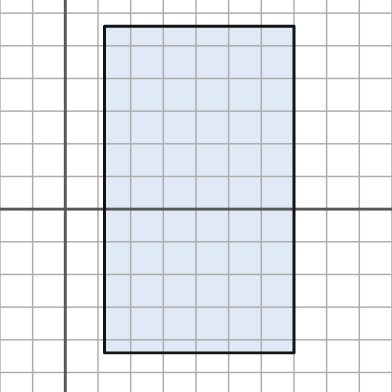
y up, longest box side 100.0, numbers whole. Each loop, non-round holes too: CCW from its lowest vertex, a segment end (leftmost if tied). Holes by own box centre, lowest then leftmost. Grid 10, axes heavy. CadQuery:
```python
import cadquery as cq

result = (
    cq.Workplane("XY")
    .moveTo(12.0, -44.0)
    .lineTo(70.0, -44.0)
    .lineTo(70.0, 56.0)
    .lineTo(12.0, 56.0)
    .close()
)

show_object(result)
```